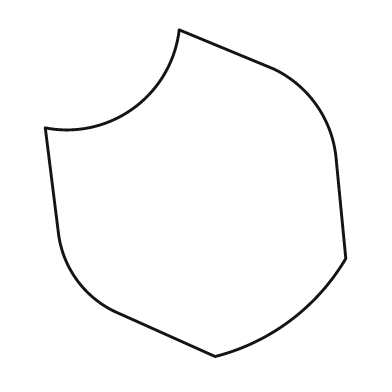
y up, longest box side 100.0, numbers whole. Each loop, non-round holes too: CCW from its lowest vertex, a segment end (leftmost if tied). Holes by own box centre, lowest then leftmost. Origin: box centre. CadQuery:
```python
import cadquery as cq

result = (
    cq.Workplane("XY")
    .moveTo(6.0, -50.0)
    .threePointArc((29.0, -39.0), (46.0, -20.0))
    .lineTo(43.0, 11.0)
    .threePointArc((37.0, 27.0), (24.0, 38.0))
    .lineTo(-5.0, 50.0)
    .threePointArc((-19.0, 26.0), (-46.0, 20.0))
    .lineTo(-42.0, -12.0)
    .threePointArc((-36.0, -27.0), (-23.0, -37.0))
    .close()
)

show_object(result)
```